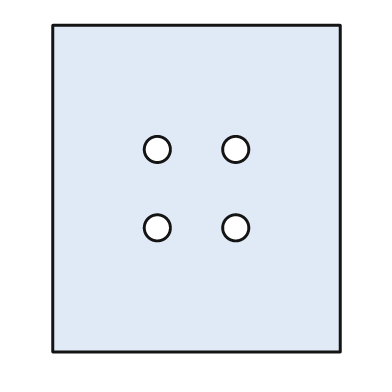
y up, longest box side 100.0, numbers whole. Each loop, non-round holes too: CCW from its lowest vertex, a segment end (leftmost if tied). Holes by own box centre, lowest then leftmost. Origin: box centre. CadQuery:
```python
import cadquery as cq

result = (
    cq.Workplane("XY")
    .moveTo(-44.0, -50.0)
    .lineTo(44.0, -50.0)
    .lineTo(44.0, 50.0)
    .lineTo(-44.0, 50.0)
    .close()
    .moveTo(-12.0, -12.0)
    .circle(4.0)
    .moveTo(12.0, -12.0)
    .circle(4.0)
    .moveTo(-12.0, 12.0)
    .circle(4.0)
    .moveTo(12.0, 12.0)
    .circle(4.0)
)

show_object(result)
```